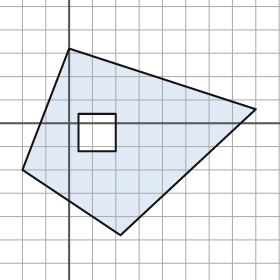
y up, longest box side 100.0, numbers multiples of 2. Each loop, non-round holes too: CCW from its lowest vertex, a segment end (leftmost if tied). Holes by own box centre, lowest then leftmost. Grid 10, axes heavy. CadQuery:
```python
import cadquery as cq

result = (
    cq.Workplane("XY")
    .moveTo(22.0, -48.0)
    .lineTo(80.0, 6.0)
    .lineTo(0.0, 32.0)
    .lineTo(-20.0, -20.0)
    .close()
    .moveTo(4.0, -12.0)
    .lineTo(20.0, -12.0)
    .lineTo(20.0, 4.0)
    .lineTo(4.0, 4.0)
    .close()
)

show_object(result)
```